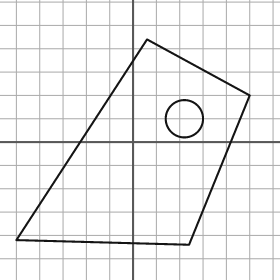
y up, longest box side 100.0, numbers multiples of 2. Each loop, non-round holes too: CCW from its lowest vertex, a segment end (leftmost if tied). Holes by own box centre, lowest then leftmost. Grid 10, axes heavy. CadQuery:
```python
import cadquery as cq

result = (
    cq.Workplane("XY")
    .moveTo(24.0, -44.0)
    .lineTo(50.0, 20.0)
    .lineTo(6.0, 44.0)
    .lineTo(-50.0, -42.0)
    .close()
    .moveTo(22.0, 10.0)
    .circle(8.0)
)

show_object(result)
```